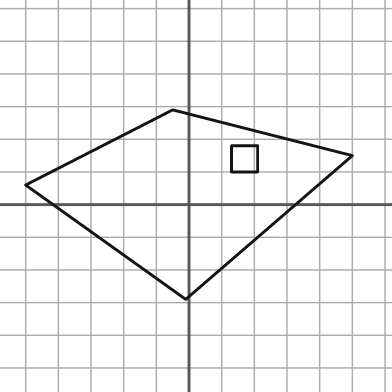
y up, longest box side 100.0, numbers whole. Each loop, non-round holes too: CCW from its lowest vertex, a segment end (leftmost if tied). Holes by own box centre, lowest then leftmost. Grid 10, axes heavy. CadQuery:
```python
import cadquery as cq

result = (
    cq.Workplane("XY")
    .moveTo(-1.0, -29.0)
    .lineTo(50.0, 15.0)
    .lineTo(-5.0, 29.0)
    .lineTo(-50.0, 6.0)
    .close()
    .moveTo(13.0, 10.0)
    .lineTo(21.0, 10.0)
    .lineTo(21.0, 18.0)
    .lineTo(13.0, 18.0)
    .close()
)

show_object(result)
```